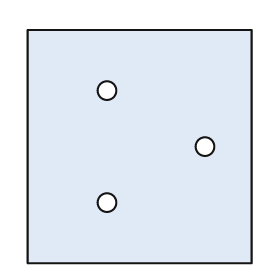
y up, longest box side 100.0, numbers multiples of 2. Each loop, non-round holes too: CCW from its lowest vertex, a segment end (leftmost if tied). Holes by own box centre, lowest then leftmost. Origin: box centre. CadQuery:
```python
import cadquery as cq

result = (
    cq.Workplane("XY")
    .moveTo(-48.0, -50.0)
    .lineTo(48.0, -50.0)
    .lineTo(48.0, 50.0)
    .lineTo(-48.0, 50.0)
    .close()
    .moveTo(-14.0, -24.0)
    .circle(4.0)
    .moveTo(28.0, 0.0)
    .circle(4.0)
    .moveTo(-14.0, 24.0)
    .circle(4.0)
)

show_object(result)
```